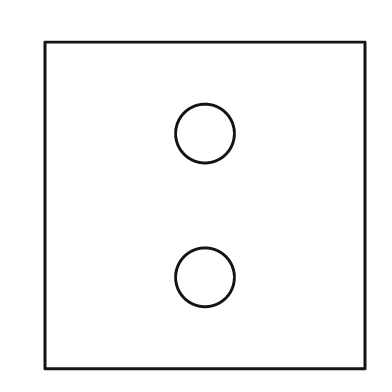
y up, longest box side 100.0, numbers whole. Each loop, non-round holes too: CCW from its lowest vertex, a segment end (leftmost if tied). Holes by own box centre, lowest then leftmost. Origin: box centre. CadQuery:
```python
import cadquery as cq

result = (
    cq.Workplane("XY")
    .moveTo(-49.0, -50.0)
    .lineTo(49.0, -50.0)
    .lineTo(49.0, 50.0)
    .lineTo(-49.0, 50.0)
    .close()
    .moveTo(0.0, -22.0)
    .circle(9.0)
    .moveTo(0.0, 22.0)
    .circle(9.0)
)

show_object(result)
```